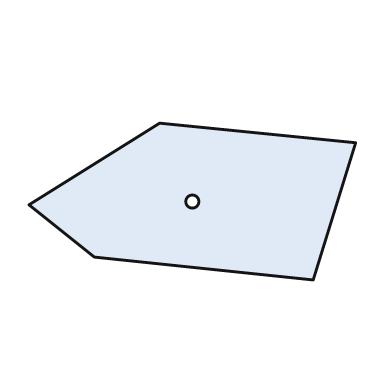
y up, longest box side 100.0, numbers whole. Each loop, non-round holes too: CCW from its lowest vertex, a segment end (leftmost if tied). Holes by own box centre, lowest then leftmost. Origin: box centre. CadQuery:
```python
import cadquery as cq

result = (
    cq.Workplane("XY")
    .moveTo(37.0, -24.0)
    .lineTo(50.0, 18.0)
    .lineTo(-10.0, 24.0)
    .lineTo(-50.0, -1.0)
    .lineTo(-30.0, -17.0)
    .close()
    .moveTo(0.0, 0.0)
    .circle(2.0)
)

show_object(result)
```